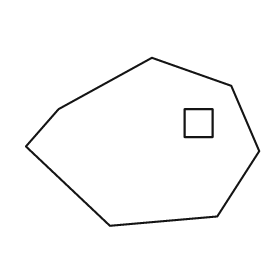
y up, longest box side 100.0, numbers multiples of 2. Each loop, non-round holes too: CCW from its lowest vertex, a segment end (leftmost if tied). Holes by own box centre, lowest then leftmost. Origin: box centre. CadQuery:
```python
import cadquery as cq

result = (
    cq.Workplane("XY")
    .moveTo(-14.0, -36.0)
    .lineTo(32.0, -32.0)
    .lineTo(50.0, -4.0)
    .lineTo(38.0, 24.0)
    .lineTo(4.0, 36.0)
    .lineTo(-36.0, 14.0)
    .lineTo(-50.0, -2.0)
    .close()
    .moveTo(18.0, 2.0)
    .lineTo(30.0, 2.0)
    .lineTo(30.0, 14.0)
    .lineTo(18.0, 14.0)
    .close()
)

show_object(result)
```